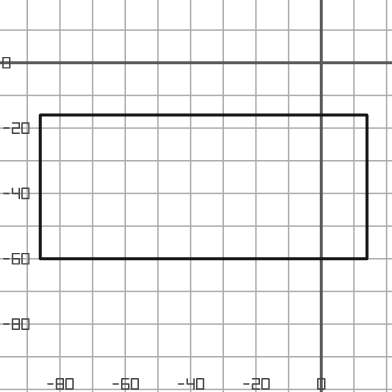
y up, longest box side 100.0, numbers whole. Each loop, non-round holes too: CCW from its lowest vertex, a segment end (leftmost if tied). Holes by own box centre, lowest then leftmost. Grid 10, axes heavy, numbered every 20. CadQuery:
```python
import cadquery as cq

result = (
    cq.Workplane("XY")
    .moveTo(-86.0, -60.0)
    .lineTo(14.0, -60.0)
    .lineTo(14.0, -16.0)
    .lineTo(-86.0, -16.0)
    .close()
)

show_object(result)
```